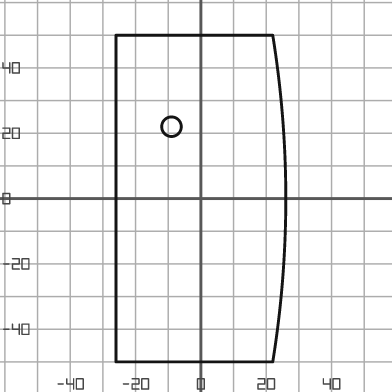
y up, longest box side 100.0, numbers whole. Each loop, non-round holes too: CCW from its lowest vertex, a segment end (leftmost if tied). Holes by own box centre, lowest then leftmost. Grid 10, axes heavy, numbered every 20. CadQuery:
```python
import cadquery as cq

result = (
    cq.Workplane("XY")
    .moveTo(-26.0, -50.0)
    .lineTo(22.0, -50.0)
    .threePointArc((26.0, 0.0), (22.0, 50.0))
    .lineTo(-26.0, 50.0)
    .close()
    .moveTo(-9.0, 22.0)
    .circle(3.0)
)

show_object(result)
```